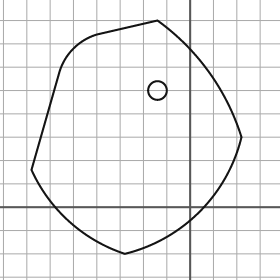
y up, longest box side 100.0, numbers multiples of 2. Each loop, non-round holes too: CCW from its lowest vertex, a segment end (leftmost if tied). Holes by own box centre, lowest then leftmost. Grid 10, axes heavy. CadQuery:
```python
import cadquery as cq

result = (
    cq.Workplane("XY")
    .moveTo(-28.0, -20.0)
    .threePointArc((4.0, -2.0), (22.0, 30.0))
    .threePointArc((8.0, 58.0), (-14.0, 80.0))
    .lineTo(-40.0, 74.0)
    .threePointArc((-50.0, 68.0), (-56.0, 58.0))
    .lineTo(-68.0, 16.0)
    .threePointArc((-52.0, -6.0), (-28.0, -20.0))
    .close()
    .moveTo(-14.0, 50.0)
    .circle(4.0)
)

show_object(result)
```